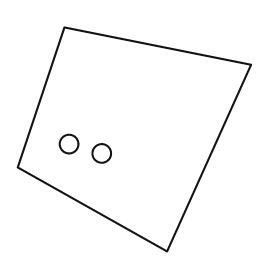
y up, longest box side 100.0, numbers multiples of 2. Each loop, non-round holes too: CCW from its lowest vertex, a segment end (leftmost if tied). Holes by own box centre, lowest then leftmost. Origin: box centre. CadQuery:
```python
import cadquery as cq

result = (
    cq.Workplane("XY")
    .moveTo(14.0, -48.0)
    .lineTo(50.0, 32.0)
    .lineTo(-30.0, 48.0)
    .lineTo(-50.0, -12.0)
    .close()
    .moveTo(-14.0, -6.0)
    .circle(4.0)
    .moveTo(-28.0, -2.0)
    .circle(4.0)
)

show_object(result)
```